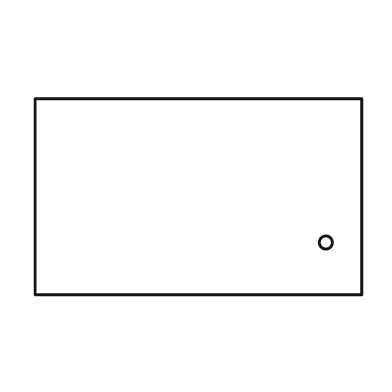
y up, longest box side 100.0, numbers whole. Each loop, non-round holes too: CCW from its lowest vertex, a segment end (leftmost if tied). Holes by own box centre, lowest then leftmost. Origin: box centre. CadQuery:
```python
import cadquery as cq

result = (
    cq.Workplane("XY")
    .moveTo(-50.0, -30.0)
    .lineTo(50.0, -30.0)
    .lineTo(50.0, 30.0)
    .lineTo(-50.0, 30.0)
    .close()
    .moveTo(39.0, -14.0)
    .circle(2.0)
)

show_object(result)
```